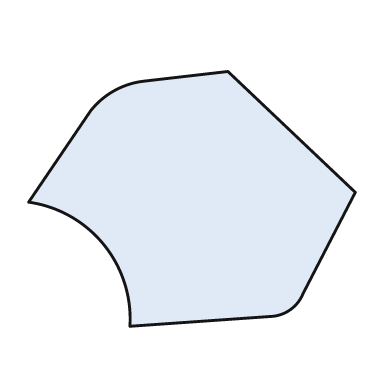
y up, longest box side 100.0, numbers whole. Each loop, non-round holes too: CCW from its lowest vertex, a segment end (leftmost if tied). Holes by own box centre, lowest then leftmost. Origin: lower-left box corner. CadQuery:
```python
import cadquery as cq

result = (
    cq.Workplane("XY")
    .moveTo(31.0, 0.0)
    .lineTo(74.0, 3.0)
    .threePointArc((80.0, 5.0), (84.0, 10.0))
    .lineTo(100.0, 41.0)
    .lineTo(61.0, 78.0)
    .lineTo(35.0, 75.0)
    .threePointArc((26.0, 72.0), (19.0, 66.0))
    .lineTo(0.0, 38.0)
    .threePointArc((23.0, 25.0), (31.0, 0.0))
    .close()
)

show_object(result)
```